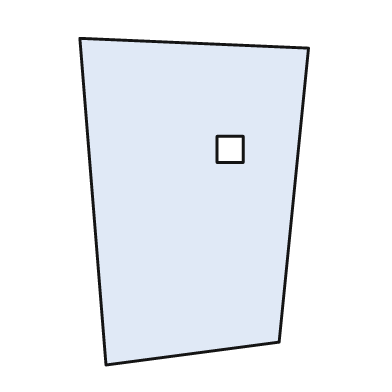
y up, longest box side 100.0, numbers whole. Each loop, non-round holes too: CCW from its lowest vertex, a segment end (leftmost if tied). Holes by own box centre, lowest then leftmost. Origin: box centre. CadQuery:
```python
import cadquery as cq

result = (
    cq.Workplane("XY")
    .moveTo(-27.0, -50.0)
    .lineTo(26.0, -43.0)
    .lineTo(35.0, 47.0)
    .lineTo(-35.0, 50.0)
    .close()
    .moveTo(7.0, 12.0)
    .lineTo(15.0, 12.0)
    .lineTo(15.0, 20.0)
    .lineTo(7.0, 20.0)
    .close()
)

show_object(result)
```